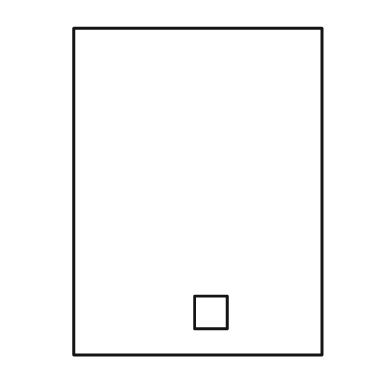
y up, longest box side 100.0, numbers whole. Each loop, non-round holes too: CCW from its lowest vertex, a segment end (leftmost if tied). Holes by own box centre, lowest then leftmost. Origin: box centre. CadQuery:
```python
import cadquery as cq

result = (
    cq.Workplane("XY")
    .moveTo(-38.0, -50.0)
    .lineTo(38.0, -50.0)
    .lineTo(38.0, 50.0)
    .lineTo(-38.0, 50.0)
    .close()
    .moveTo(-1.0, -42.0)
    .lineTo(9.0, -42.0)
    .lineTo(9.0, -32.0)
    .lineTo(-1.0, -32.0)
    .close()
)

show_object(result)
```